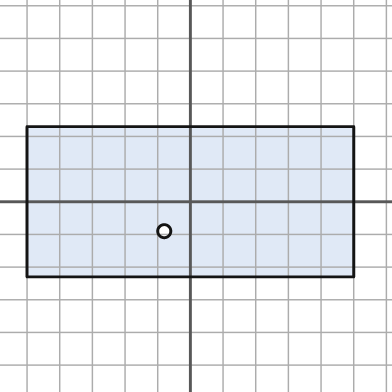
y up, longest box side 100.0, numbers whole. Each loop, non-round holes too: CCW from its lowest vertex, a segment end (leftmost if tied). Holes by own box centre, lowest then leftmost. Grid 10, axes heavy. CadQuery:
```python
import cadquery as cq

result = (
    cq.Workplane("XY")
    .moveTo(-50.0, -23.0)
    .lineTo(50.0, -23.0)
    .lineTo(50.0, 23.0)
    .lineTo(-50.0, 23.0)
    .close()
    .moveTo(-8.0, -9.0)
    .circle(2.0)
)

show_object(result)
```